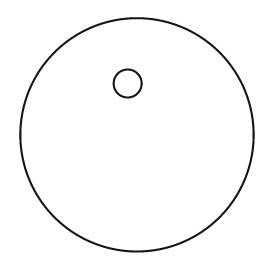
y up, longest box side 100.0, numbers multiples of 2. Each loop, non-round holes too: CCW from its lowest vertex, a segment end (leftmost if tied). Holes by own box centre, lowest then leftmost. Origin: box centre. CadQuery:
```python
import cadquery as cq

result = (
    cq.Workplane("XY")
    .moveTo(0.0, 0.0)
    .circle(50.0)
    .moveTo(-4.0, 22.0)
    .circle(6.0)
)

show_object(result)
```